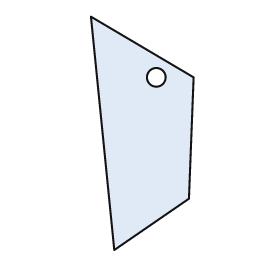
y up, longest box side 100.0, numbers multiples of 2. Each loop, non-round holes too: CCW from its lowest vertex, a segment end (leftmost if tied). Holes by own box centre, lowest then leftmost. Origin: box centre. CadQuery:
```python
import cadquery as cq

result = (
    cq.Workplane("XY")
    .moveTo(-12.0, -50.0)
    .lineTo(20.0, -28.0)
    .lineTo(22.0, 24.0)
    .lineTo(-22.0, 50.0)
    .close()
    .moveTo(6.0, 24.0)
    .circle(4.0)
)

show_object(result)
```